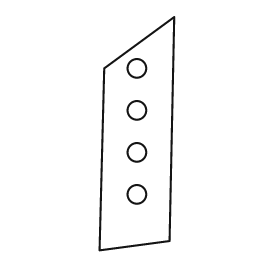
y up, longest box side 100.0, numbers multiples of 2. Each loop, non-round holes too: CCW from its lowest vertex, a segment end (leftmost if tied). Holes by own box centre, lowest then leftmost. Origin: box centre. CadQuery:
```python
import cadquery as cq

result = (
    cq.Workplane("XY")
    .moveTo(-16.0, -50.0)
    .lineTo(14.0, -46.0)
    .lineTo(16.0, 50.0)
    .lineTo(-14.0, 28.0)
    .close()
    .moveTo(0.0, -26.0)
    .circle(4.0)
    .moveTo(0.0, -8.0)
    .circle(4.0)
    .moveTo(0.0, 10.0)
    .circle(4.0)
    .moveTo(0.0, 28.0)
    .circle(4.0)
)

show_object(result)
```